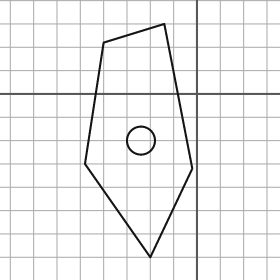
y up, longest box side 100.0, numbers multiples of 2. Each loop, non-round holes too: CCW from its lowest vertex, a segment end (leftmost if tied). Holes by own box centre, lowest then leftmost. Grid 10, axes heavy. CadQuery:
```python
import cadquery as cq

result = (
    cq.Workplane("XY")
    .moveTo(-20.0, -70.0)
    .lineTo(-2.0, -32.0)
    .lineTo(-14.0, 30.0)
    .lineTo(-40.0, 22.0)
    .lineTo(-48.0, -30.0)
    .close()
    .moveTo(-24.0, -20.0)
    .circle(6.0)
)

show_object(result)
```